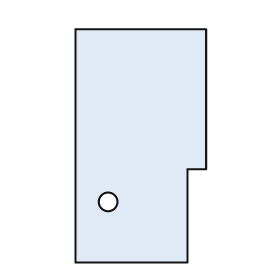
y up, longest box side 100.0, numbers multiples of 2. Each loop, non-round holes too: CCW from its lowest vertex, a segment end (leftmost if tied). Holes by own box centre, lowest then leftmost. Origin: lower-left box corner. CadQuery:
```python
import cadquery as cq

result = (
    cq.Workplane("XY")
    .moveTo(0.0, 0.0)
    .lineTo(48.0, 0.0)
    .lineTo(48.0, 40.0)
    .lineTo(56.0, 40.0)
    .lineTo(56.0, 100.0)
    .lineTo(0.0, 100.0)
    .close()
    .moveTo(14.0, 26.0)
    .circle(4.0)
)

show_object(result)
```